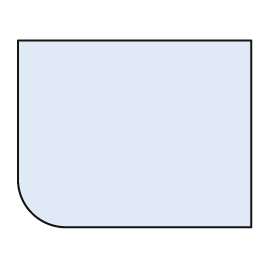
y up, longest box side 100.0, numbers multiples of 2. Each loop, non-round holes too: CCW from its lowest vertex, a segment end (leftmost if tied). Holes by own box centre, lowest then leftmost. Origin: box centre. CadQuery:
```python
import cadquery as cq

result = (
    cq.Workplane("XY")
    .moveTo(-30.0, -40.0)
    .lineTo(50.0, -40.0)
    .lineTo(50.0, 40.0)
    .lineTo(-50.0, 40.0)
    .lineTo(-50.0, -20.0)
    .threePointArc((-44.0, -34.0), (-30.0, -40.0))
    .close()
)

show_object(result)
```